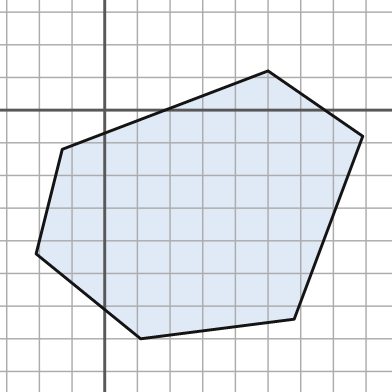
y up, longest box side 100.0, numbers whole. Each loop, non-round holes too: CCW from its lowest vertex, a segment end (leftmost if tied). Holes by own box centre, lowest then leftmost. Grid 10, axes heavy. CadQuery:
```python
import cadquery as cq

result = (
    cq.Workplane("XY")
    .moveTo(11.0, -70.0)
    .lineTo(58.0, -64.0)
    .lineTo(79.0, -8.0)
    .lineTo(50.0, 12.0)
    .lineTo(-13.0, -12.0)
    .lineTo(-21.0, -44.0)
    .close()
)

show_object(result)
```